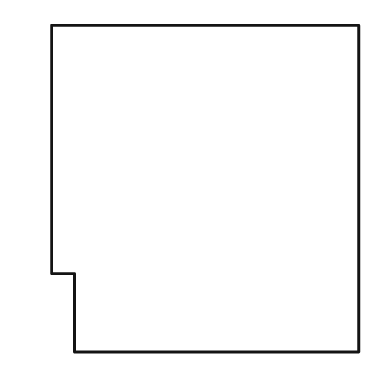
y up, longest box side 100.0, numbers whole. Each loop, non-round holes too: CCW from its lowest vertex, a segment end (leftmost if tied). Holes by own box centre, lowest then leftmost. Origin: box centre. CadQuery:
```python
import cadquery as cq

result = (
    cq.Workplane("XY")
    .moveTo(-40.0, -50.0)
    .lineTo(47.0, -50.0)
    .lineTo(47.0, 50.0)
    .lineTo(-47.0, 50.0)
    .lineTo(-47.0, -26.0)
    .lineTo(-40.0, -26.0)
    .close()
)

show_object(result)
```